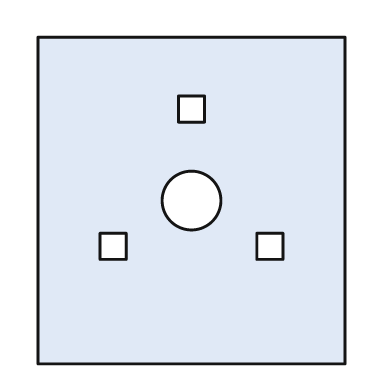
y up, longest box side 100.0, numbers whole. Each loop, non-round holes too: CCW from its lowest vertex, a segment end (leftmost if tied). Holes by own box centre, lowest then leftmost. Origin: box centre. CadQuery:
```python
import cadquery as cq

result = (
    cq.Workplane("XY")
    .moveTo(-47.0, -50.0)
    .lineTo(47.0, -50.0)
    .lineTo(47.0, 50.0)
    .lineTo(-47.0, 50.0)
    .close()
    .moveTo(-28.0, -18.0)
    .lineTo(-20.0, -18.0)
    .lineTo(-20.0, -10.0)
    .lineTo(-28.0, -10.0)
    .close()
    .moveTo(20.0, -18.0)
    .lineTo(28.0, -18.0)
    .lineTo(28.0, -10.0)
    .lineTo(20.0, -10.0)
    .close()
    .moveTo(0.0, 0.0)
    .circle(9.0)
    .moveTo(-4.0, 24.0)
    .lineTo(4.0, 24.0)
    .lineTo(4.0, 32.0)
    .lineTo(-4.0, 32.0)
    .close()
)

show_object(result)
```